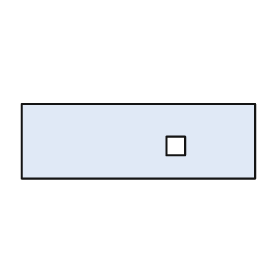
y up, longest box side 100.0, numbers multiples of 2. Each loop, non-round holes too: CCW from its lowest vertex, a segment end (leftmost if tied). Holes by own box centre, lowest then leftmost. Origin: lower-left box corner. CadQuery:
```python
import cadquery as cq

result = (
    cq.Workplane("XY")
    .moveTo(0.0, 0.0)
    .lineTo(100.0, 0.0)
    .lineTo(100.0, 32.0)
    .lineTo(0.0, 32.0)
    .close()
    .moveTo(62.0, 10.0)
    .lineTo(70.0, 10.0)
    .lineTo(70.0, 18.0)
    .lineTo(62.0, 18.0)
    .close()
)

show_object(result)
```